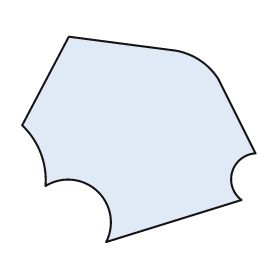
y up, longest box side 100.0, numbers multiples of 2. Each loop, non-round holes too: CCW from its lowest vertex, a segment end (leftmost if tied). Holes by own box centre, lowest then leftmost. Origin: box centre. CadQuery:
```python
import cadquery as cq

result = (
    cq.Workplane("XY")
    .moveTo(-14.0, -44.0)
    .lineTo(44.0, -26.0)
    .threePointArc((40.0, -14.0), (50.0, -6.0))
    .lineTo(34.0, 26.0)
    .threePointArc((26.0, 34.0), (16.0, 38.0))
    .lineTo(-30.0, 44.0)
    .lineTo(-50.0, 6.0)
    .threePointArc((-42.0, -6.0), (-40.0, -20.0))
    .threePointArc((-18.0, -22.0), (-14.0, -44.0))
    .close()
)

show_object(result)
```